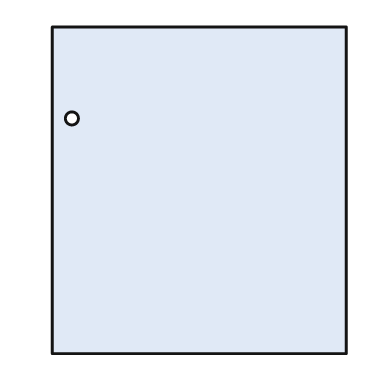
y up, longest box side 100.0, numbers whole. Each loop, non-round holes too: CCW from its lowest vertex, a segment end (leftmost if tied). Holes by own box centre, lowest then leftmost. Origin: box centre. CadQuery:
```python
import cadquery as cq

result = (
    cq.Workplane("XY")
    .moveTo(-45.0, -50.0)
    .lineTo(45.0, -50.0)
    .lineTo(45.0, 50.0)
    .lineTo(-45.0, 50.0)
    .close()
    .moveTo(-39.0, 22.0)
    .circle(2.0)
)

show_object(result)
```